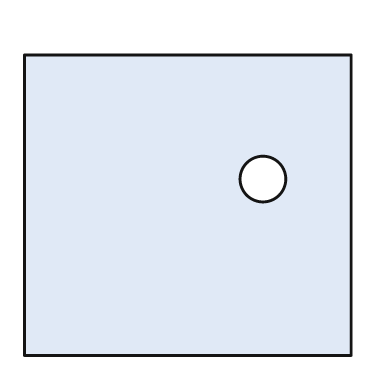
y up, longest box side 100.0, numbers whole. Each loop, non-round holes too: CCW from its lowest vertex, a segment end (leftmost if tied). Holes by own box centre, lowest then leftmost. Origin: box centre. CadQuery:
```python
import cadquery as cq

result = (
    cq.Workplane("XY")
    .moveTo(-50.0, -46.0)
    .lineTo(50.0, -46.0)
    .lineTo(50.0, 46.0)
    .lineTo(-50.0, 46.0)
    .close()
    .moveTo(23.0, 8.0)
    .circle(7.0)
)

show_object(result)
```